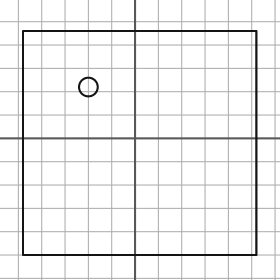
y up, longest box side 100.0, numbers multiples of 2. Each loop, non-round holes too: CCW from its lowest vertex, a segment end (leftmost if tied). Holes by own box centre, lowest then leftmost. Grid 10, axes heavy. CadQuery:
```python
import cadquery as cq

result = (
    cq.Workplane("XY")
    .moveTo(-48.0, -50.0)
    .lineTo(52.0, -50.0)
    .lineTo(52.0, 46.0)
    .lineTo(-48.0, 46.0)
    .close()
    .moveTo(-20.0, 22.0)
    .circle(4.0)
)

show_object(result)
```